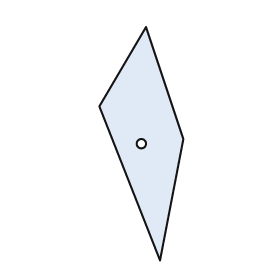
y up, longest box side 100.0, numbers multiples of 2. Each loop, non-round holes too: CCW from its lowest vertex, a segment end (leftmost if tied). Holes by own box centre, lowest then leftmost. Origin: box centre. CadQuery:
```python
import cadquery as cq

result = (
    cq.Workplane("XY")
    .moveTo(8.0, -50.0)
    .lineTo(18.0, 2.0)
    .lineTo(2.0, 50.0)
    .lineTo(-18.0, 16.0)
    .close()
    .moveTo(0.0, 0.0)
    .circle(2.0)
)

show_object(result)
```